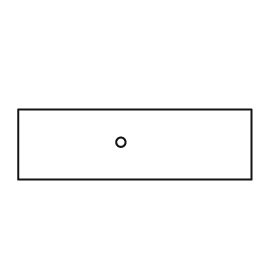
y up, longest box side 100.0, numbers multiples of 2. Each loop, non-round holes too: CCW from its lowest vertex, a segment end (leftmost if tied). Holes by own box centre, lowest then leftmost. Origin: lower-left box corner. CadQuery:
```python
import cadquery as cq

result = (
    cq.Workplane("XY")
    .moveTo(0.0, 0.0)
    .lineTo(100.0, 0.0)
    .lineTo(100.0, 30.0)
    .lineTo(0.0, 30.0)
    .close()
    .moveTo(44.0, 16.0)
    .circle(2.0)
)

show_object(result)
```